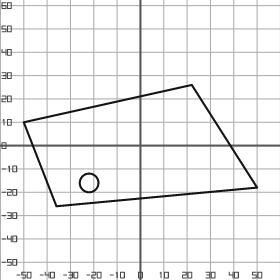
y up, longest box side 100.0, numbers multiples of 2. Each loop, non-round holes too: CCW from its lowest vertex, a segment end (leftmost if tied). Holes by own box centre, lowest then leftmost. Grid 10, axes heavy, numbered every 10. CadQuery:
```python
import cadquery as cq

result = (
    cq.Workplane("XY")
    .moveTo(-36.0, -26.0)
    .lineTo(50.0, -18.0)
    .lineTo(22.0, 26.0)
    .lineTo(-50.0, 10.0)
    .close()
    .moveTo(-22.0, -16.0)
    .circle(4.0)
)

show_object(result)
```